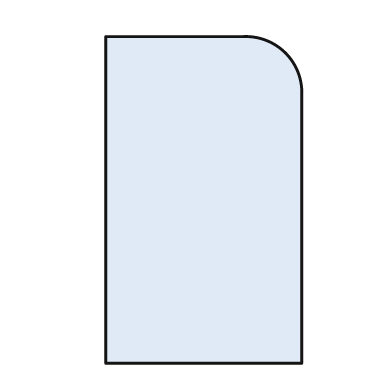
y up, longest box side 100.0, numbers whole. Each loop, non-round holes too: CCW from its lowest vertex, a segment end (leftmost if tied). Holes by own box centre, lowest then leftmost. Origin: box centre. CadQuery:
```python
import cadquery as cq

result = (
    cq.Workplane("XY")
    .moveTo(-30.0, -50.0)
    .lineTo(30.0, -50.0)
    .lineTo(30.0, 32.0)
    .threePointArc((25.0, 45.0), (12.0, 50.0))
    .lineTo(-30.0, 50.0)
    .close()
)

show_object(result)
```